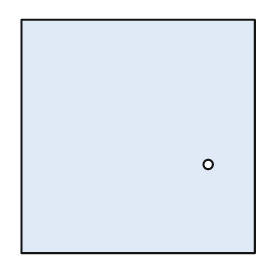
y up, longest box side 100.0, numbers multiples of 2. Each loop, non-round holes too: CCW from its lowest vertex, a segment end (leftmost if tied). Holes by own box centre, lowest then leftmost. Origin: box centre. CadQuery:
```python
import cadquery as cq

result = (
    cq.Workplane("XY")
    .moveTo(-50.0, -50.0)
    .lineTo(50.0, -50.0)
    .lineTo(50.0, 50.0)
    .lineTo(-50.0, 50.0)
    .close()
    .moveTo(30.0, -12.0)
    .circle(2.0)
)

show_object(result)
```